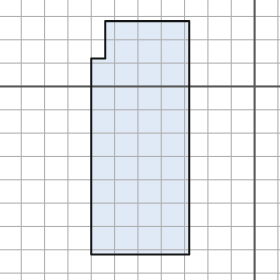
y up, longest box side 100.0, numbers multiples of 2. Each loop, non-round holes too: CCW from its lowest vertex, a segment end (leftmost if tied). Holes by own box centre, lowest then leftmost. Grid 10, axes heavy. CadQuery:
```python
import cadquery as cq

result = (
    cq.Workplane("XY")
    .moveTo(-70.0, -72.0)
    .lineTo(-28.0, -72.0)
    .lineTo(-28.0, 28.0)
    .lineTo(-64.0, 28.0)
    .lineTo(-64.0, 12.0)
    .lineTo(-70.0, 12.0)
    .close()
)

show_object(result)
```